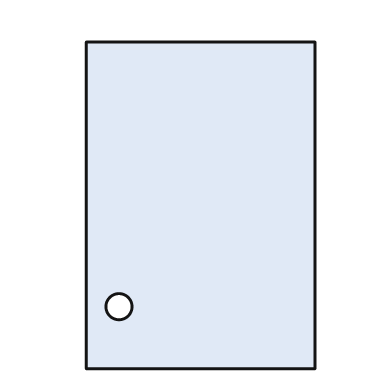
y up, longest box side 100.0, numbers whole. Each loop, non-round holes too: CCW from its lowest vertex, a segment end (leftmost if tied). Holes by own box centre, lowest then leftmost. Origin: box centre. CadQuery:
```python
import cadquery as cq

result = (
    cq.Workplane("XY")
    .moveTo(-35.0, -50.0)
    .lineTo(35.0, -50.0)
    .lineTo(35.0, 50.0)
    .lineTo(-35.0, 50.0)
    .close()
    .moveTo(-25.0, -31.0)
    .circle(4.0)
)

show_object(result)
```